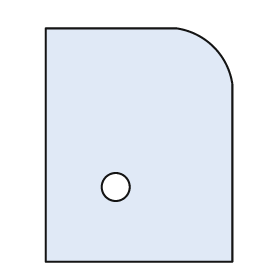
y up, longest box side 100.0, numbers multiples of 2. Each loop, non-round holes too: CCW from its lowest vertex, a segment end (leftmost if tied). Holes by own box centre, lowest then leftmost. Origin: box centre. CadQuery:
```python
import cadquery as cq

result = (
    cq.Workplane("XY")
    .moveTo(-40.0, -50.0)
    .lineTo(40.0, -50.0)
    .lineTo(40.0, 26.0)
    .threePointArc((32.0, 42.0), (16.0, 50.0))
    .lineTo(-40.0, 50.0)
    .close()
    .moveTo(-10.0, -18.0)
    .circle(6.0)
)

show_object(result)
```